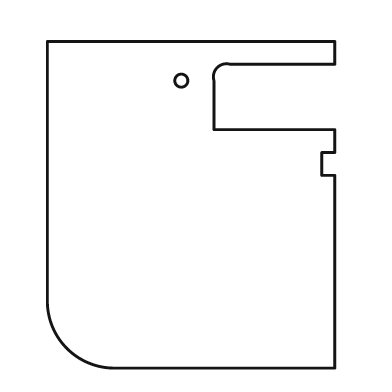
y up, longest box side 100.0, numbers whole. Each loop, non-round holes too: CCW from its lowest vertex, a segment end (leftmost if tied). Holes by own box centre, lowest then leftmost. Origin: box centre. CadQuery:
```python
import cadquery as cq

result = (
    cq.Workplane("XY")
    .moveTo(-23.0, -50.0)
    .lineTo(44.0, -50.0)
    .lineTo(44.0, 9.0)
    .lineTo(40.0, 9.0)
    .lineTo(40.0, 16.0)
    .lineTo(44.0, 16.0)
    .lineTo(44.0, 23.0)
    .lineTo(7.0, 23.0)
    .lineTo(7.0, 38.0)
    .threePointArc((8.0, 42.0), (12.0, 43.0))
    .lineTo(44.0, 43.0)
    .lineTo(44.0, 50.0)
    .lineTo(-44.0, 50.0)
    .lineTo(-44.0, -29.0)
    .threePointArc((-38.0, -44.0), (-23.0, -50.0))
    .close()
    .moveTo(-3.0, 38.0)
    .circle(2.0)
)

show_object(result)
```